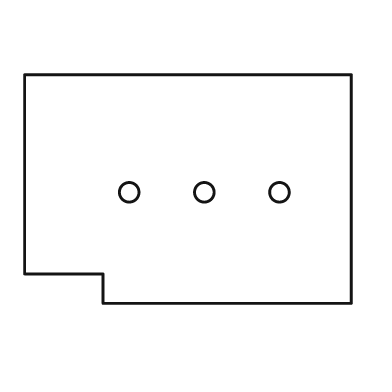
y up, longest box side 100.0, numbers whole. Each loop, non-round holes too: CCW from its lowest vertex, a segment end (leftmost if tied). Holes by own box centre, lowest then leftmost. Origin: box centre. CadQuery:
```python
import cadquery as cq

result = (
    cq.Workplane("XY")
    .moveTo(-26.0, -35.0)
    .lineTo(50.0, -35.0)
    .lineTo(50.0, 35.0)
    .lineTo(-50.0, 35.0)
    .lineTo(-50.0, -26.0)
    .lineTo(-26.0, -26.0)
    .close()
    .moveTo(-18.0, -1.0)
    .circle(3.0)
    .moveTo(5.0, -1.0)
    .circle(3.0)
    .moveTo(28.0, -1.0)
    .circle(3.0)
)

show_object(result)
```